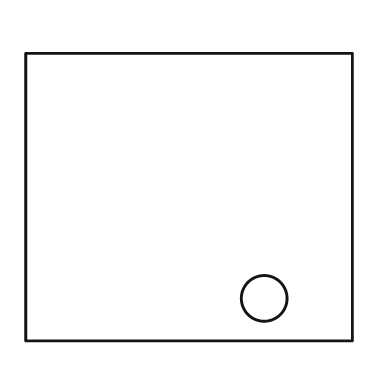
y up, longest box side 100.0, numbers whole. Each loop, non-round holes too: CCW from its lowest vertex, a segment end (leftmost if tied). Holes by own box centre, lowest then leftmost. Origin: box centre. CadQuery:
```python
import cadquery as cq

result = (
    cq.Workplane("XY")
    .moveTo(-50.0, -44.0)
    .lineTo(50.0, -44.0)
    .lineTo(50.0, 44.0)
    .lineTo(-50.0, 44.0)
    .close()
    .moveTo(23.0, -31.0)
    .circle(7.0)
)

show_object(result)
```